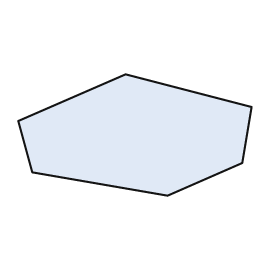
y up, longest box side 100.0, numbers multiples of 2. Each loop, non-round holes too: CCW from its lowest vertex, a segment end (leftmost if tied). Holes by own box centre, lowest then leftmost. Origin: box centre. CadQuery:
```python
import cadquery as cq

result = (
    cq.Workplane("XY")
    .moveTo(14.0, -26.0)
    .lineTo(46.0, -12.0)
    .lineTo(50.0, 12.0)
    .lineTo(-4.0, 26.0)
    .lineTo(-50.0, 6.0)
    .lineTo(-44.0, -16.0)
    .close()
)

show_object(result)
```